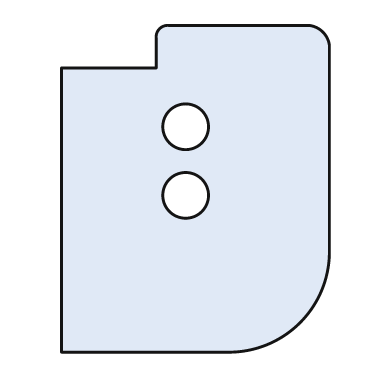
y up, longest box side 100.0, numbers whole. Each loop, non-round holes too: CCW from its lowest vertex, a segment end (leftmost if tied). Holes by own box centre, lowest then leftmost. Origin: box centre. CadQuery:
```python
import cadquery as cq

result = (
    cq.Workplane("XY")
    .moveTo(-41.0, -50.0)
    .lineTo(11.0, -50.0)
    .threePointArc((32.0, -41.0), (41.0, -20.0))
    .lineTo(41.0, 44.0)
    .threePointArc((39.0, 48.0), (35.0, 50.0))
    .lineTo(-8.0, 50.0)
    .threePointArc((-11.0, 49.0), (-12.0, 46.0))
    .lineTo(-12.0, 37.0)
    .lineTo(-41.0, 37.0)
    .close()
    .moveTo(-3.0, -2.0)
    .circle(7.0)
    .moveTo(-3.0, 19.0)
    .circle(7.0)
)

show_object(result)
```